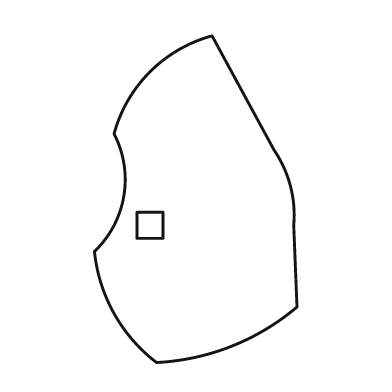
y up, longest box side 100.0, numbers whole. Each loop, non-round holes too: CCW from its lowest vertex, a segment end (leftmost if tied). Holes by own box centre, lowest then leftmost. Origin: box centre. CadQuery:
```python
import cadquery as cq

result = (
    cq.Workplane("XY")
    .moveTo(-12.0, -50.0)
    .threePointArc((11.0, -45.0), (31.0, -33.0))
    .lineTo(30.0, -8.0)
    .threePointArc((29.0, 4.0), (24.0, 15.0))
    .lineTo(5.0, 50.0)
    .threePointArc((-14.0, 39.0), (-25.0, 20.0))
    .threePointArc((-22.0, 1.0), (-31.0, -16.0))
    .threePointArc((-25.0, -35.0), (-12.0, -50.0))
    .close()
    .moveTo(-18.0, -12.0)
    .lineTo(-10.0, -12.0)
    .lineTo(-10.0, -4.0)
    .lineTo(-18.0, -4.0)
    .close()
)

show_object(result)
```